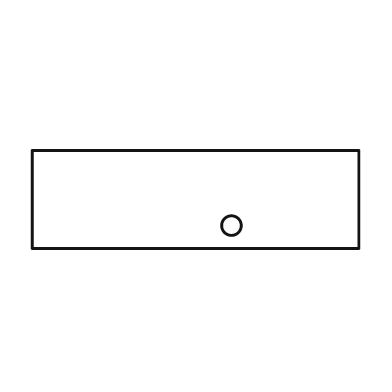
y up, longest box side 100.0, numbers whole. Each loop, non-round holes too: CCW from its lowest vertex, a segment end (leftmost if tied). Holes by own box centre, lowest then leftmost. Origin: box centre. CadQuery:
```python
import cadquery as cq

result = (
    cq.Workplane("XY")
    .moveTo(-50.0, -15.0)
    .lineTo(50.0, -15.0)
    .lineTo(50.0, 15.0)
    .lineTo(-50.0, 15.0)
    .close()
    .moveTo(11.0, -8.0)
    .circle(3.0)
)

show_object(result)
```